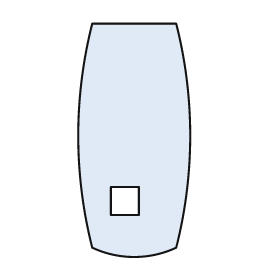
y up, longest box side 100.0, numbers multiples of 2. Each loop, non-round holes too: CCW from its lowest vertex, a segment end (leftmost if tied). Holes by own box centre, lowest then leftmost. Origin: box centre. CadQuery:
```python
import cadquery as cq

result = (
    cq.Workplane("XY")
    .moveTo(-18.0, -46.0)
    .threePointArc((0.0, -50.0), (18.0, -46.0))
    .threePointArc((24.0, 2.0), (18.0, 50.0))
    .lineTo(-18.0, 50.0)
    .threePointArc((-24.0, 2.0), (-18.0, -46.0))
    .close()
    .moveTo(-10.0, -32.0)
    .lineTo(2.0, -32.0)
    .lineTo(2.0, -20.0)
    .lineTo(-10.0, -20.0)
    .close()
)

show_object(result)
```